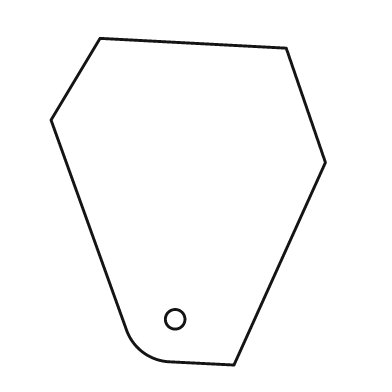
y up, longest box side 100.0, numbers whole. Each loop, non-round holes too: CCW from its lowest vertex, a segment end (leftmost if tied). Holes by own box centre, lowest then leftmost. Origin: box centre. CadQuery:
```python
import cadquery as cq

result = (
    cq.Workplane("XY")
    .moveTo(14.0, -50.0)
    .lineTo(42.0, 12.0)
    .lineTo(30.0, 47.0)
    .lineTo(-27.0, 50.0)
    .lineTo(-42.0, 25.0)
    .lineTo(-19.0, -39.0)
    .threePointArc((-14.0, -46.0), (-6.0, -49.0))
    .close()
    .moveTo(-4.0, -36.0)
    .circle(3.0)
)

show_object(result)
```